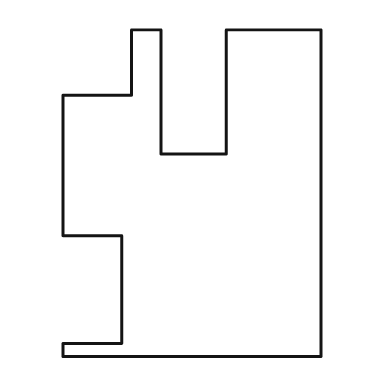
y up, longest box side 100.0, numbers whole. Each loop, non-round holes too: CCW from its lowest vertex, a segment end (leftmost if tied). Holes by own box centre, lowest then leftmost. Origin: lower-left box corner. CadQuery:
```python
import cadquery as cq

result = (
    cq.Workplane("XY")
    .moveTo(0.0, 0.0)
    .lineTo(79.0, 0.0)
    .lineTo(79.0, 100.0)
    .lineTo(50.0, 100.0)
    .lineTo(50.0, 62.0)
    .lineTo(30.0, 62.0)
    .lineTo(30.0, 100.0)
    .lineTo(21.0, 100.0)
    .lineTo(21.0, 80.0)
    .lineTo(0.0, 80.0)
    .lineTo(0.0, 37.0)
    .lineTo(18.0, 37.0)
    .lineTo(18.0, 4.0)
    .lineTo(0.0, 4.0)
    .close()
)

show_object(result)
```